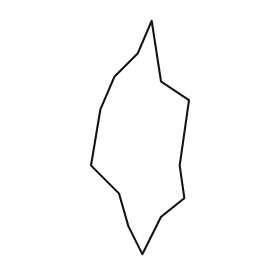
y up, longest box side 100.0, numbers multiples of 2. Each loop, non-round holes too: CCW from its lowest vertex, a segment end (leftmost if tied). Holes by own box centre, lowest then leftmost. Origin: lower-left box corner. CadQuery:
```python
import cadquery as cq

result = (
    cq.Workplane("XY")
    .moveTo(22.0, 0.0)
    .lineTo(30.0, 16.0)
    .lineTo(40.0, 24.0)
    .lineTo(38.0, 38.0)
    .lineTo(42.0, 66.0)
    .lineTo(30.0, 74.0)
    .lineTo(26.0, 100.0)
    .lineTo(20.0, 86.0)
    .lineTo(10.0, 76.0)
    .lineTo(4.0, 62.0)
    .lineTo(0.0, 38.0)
    .lineTo(12.0, 26.0)
    .lineTo(16.0, 12.0)
    .close()
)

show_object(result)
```